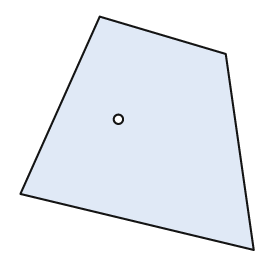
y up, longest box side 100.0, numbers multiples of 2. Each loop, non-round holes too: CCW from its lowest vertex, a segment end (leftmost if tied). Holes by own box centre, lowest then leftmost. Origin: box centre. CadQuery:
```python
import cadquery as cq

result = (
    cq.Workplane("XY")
    .moveTo(50.0, -50.0)
    .lineTo(38.0, 34.0)
    .lineTo(-16.0, 50.0)
    .lineTo(-50.0, -26.0)
    .close()
    .moveTo(-8.0, 6.0)
    .circle(2.0)
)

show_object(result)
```